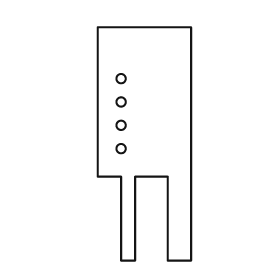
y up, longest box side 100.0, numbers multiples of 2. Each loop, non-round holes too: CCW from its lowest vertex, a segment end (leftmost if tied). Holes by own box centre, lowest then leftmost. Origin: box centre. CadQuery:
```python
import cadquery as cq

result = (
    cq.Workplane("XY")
    .moveTo(-10.0, -50.0)
    .lineTo(-4.0, -50.0)
    .lineTo(-4.0, -14.0)
    .lineTo(10.0, -14.0)
    .lineTo(10.0, -50.0)
    .lineTo(20.0, -50.0)
    .lineTo(20.0, 50.0)
    .lineTo(-20.0, 50.0)
    .lineTo(-20.0, -14.0)
    .lineTo(-10.0, -14.0)
    .close()
    .moveTo(-10.0, -2.0)
    .circle(2.0)
    .moveTo(-10.0, 8.0)
    .circle(2.0)
    .moveTo(-10.0, 18.0)
    .circle(2.0)
    .moveTo(-10.0, 28.0)
    .circle(2.0)
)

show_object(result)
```